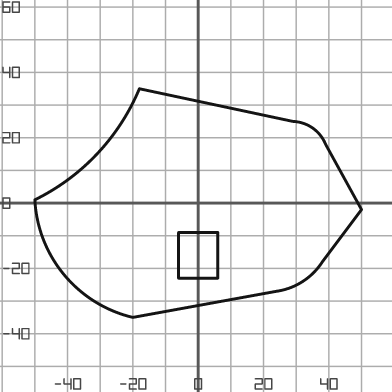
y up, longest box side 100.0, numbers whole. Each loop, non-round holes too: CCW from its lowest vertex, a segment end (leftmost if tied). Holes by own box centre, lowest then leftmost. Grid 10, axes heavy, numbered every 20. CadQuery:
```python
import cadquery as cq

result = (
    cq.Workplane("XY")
    .moveTo(-20.0, -35.0)
    .lineTo(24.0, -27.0)
    .threePointArc((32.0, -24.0), (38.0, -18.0))
    .lineTo(50.0, -2.0)
    .lineTo(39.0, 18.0)
    .threePointArc((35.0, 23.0), (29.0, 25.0))
    .lineTo(-18.0, 35.0)
    .threePointArc((-31.0, 15.0), (-50.0, 1.0))
    .threePointArc((-41.0, -22.0), (-20.0, -35.0))
    .close()
    .moveTo(-6.0, -23.0)
    .lineTo(6.0, -23.0)
    .lineTo(6.0, -9.0)
    .lineTo(-6.0, -9.0)
    .close()
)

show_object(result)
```